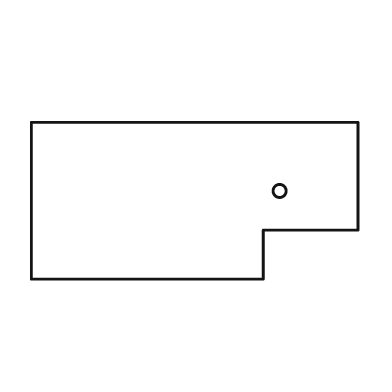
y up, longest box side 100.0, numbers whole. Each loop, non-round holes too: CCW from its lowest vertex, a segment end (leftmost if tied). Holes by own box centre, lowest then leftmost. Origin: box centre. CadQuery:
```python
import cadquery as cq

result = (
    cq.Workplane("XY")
    .moveTo(-50.0, -24.0)
    .lineTo(21.0, -24.0)
    .lineTo(21.0, -9.0)
    .lineTo(50.0, -9.0)
    .lineTo(50.0, 24.0)
    .lineTo(-50.0, 24.0)
    .close()
    .moveTo(26.0, 3.0)
    .circle(2.0)
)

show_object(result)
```